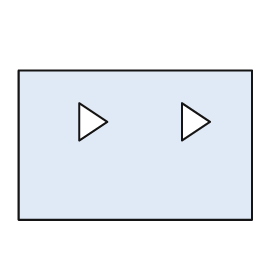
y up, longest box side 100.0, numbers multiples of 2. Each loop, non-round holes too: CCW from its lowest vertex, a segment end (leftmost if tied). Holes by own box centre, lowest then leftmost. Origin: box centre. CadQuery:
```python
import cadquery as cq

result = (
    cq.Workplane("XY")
    .moveTo(-50.0, -32.0)
    .lineTo(50.0, -32.0)
    .lineTo(50.0, 32.0)
    .lineTo(-50.0, 32.0)
    .close()
    .moveTo(-24.0, 2.0)
    .lineTo(-12.0, 10.0)
    .lineTo(-24.0, 18.0)
    .close()
    .moveTo(20.0, 2.0)
    .lineTo(32.0, 10.0)
    .lineTo(20.0, 18.0)
    .close()
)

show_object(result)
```